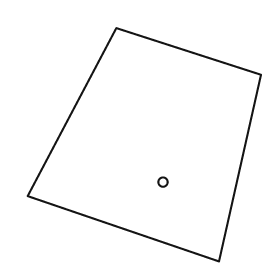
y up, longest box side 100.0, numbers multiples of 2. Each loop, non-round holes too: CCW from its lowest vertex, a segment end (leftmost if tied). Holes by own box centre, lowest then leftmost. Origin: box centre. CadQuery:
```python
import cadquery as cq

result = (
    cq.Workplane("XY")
    .moveTo(32.0, -50.0)
    .lineTo(50.0, 30.0)
    .lineTo(-12.0, 50.0)
    .lineTo(-50.0, -22.0)
    .close()
    .moveTo(8.0, -16.0)
    .circle(2.0)
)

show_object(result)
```